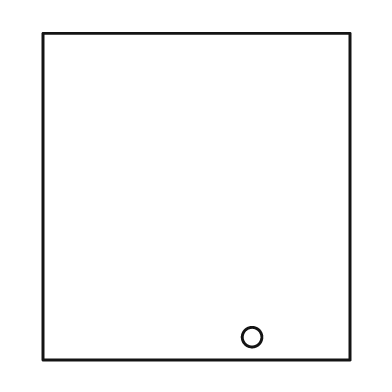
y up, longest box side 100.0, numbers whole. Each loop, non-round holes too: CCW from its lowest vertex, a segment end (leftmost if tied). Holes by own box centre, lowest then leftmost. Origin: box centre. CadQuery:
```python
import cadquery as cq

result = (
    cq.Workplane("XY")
    .moveTo(-47.0, -50.0)
    .lineTo(47.0, -50.0)
    .lineTo(47.0, 50.0)
    .lineTo(-47.0, 50.0)
    .close()
    .moveTo(17.0, -43.0)
    .circle(3.0)
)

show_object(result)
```